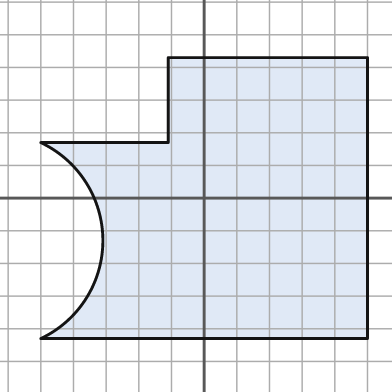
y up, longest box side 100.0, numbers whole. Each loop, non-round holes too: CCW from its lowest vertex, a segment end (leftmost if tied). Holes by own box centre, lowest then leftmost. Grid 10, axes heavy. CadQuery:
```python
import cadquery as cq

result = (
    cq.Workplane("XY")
    .moveTo(-50.0, -43.0)
    .lineTo(50.0, -43.0)
    .lineTo(50.0, 43.0)
    .lineTo(-11.0, 43.0)
    .lineTo(-11.0, 17.0)
    .lineTo(-50.0, 17.0)
    .threePointArc((-31.0, -13.0), (-50.0, -43.0))
    .close()
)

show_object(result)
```